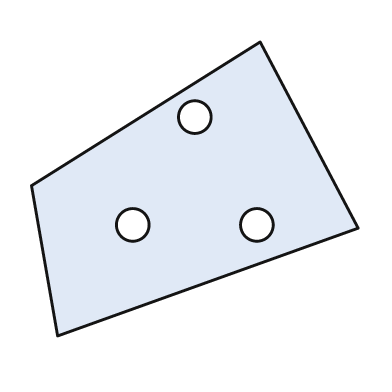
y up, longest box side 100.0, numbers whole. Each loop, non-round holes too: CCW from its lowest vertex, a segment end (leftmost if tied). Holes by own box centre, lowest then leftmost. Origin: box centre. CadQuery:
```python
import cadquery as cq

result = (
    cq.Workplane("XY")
    .moveTo(-42.0, -45.0)
    .lineTo(50.0, -12.0)
    .lineTo(20.0, 45.0)
    .lineTo(-50.0, 1.0)
    .close()
    .moveTo(-19.0, -11.0)
    .circle(5.0)
    .moveTo(19.0, -11.0)
    .circle(5.0)
    .moveTo(0.0, 22.0)
    .circle(5.0)
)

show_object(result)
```